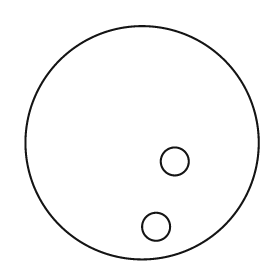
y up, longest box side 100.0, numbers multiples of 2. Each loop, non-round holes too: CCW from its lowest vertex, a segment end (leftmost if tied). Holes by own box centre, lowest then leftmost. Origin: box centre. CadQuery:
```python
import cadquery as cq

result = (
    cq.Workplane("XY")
    .moveTo(0.0, 0.0)
    .circle(50.0)
    .moveTo(6.0, -36.0)
    .circle(6.0)
    .moveTo(14.0, -8.0)
    .circle(6.0)
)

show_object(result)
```